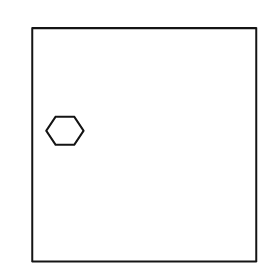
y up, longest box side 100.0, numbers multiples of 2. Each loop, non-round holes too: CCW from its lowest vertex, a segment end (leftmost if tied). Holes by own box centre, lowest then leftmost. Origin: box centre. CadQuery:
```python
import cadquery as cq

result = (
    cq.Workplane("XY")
    .moveTo(-48.0, -50.0)
    .lineTo(48.0, -50.0)
    .lineTo(48.0, 50.0)
    .lineTo(-48.0, 50.0)
    .close()
    .moveTo(-38.0, 0.0)
    .lineTo(-30.0, 0.0)
    .lineTo(-26.0, 6.0)
    .lineTo(-30.0, 12.0)
    .lineTo(-38.0, 12.0)
    .lineTo(-42.0, 6.0)
    .close()
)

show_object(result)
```